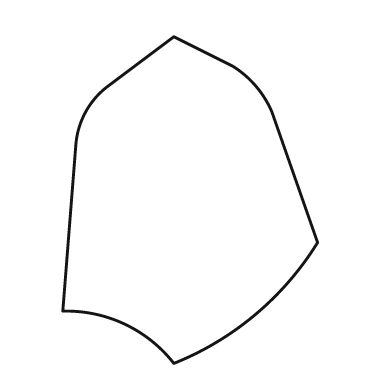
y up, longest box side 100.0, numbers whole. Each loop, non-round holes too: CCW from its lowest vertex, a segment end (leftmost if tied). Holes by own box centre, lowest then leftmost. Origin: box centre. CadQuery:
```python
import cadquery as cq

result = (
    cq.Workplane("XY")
    .moveTo(-5.0, -50.0)
    .threePointArc((20.0, -35.0), (39.0, -13.0))
    .lineTo(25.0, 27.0)
    .threePointArc((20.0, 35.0), (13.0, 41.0))
    .lineTo(-5.0, 50.0)
    .lineTo(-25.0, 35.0)
    .threePointArc((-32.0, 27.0), (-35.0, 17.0))
    .lineTo(-39.0, -34.0)
    .threePointArc((-20.0, -38.0), (-5.0, -50.0))
    .close()
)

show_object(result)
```